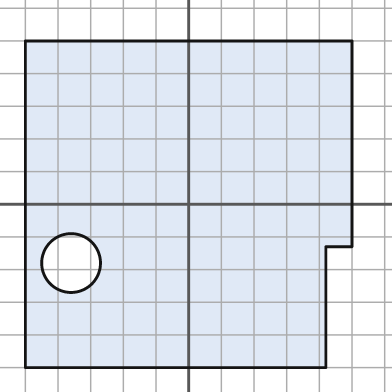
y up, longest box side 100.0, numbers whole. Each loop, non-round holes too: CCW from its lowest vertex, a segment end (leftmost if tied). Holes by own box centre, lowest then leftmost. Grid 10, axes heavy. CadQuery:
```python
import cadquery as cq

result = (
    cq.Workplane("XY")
    .moveTo(-50.0, -50.0)
    .lineTo(42.0, -50.0)
    .lineTo(42.0, -13.0)
    .lineTo(50.0, -13.0)
    .lineTo(50.0, 50.0)
    .lineTo(-50.0, 50.0)
    .close()
    .moveTo(-36.0, -18.0)
    .circle(9.0)
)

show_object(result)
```